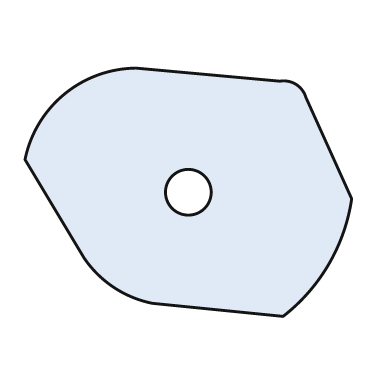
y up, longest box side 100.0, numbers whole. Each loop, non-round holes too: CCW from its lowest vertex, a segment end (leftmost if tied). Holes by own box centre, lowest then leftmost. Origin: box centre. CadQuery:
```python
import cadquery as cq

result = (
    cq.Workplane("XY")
    .moveTo(29.0, -38.0)
    .threePointArc((43.0, -22.0), (50.0, -2.0))
    .lineTo(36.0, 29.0)
    .threePointArc((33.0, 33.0), (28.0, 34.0))
    .lineTo(-16.0, 38.0)
    .threePointArc((-38.0, 30.0), (-50.0, 10.0))
    .lineTo(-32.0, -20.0)
    .threePointArc((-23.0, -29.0), (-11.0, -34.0))
    .close()
    .moveTo(0.0, 0.0)
    .circle(7.0)
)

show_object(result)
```